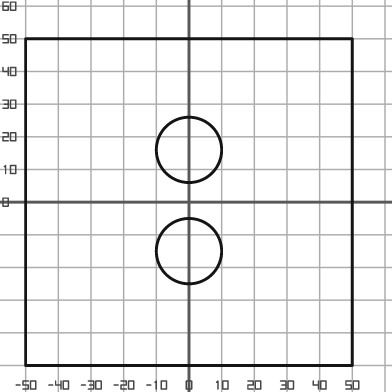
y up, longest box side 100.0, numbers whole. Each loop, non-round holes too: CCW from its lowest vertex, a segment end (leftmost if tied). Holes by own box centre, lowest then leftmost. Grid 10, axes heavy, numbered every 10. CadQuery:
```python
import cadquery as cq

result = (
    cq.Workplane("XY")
    .moveTo(-50.0, -50.0)
    .lineTo(50.0, -50.0)
    .lineTo(50.0, 50.0)
    .lineTo(-50.0, 50.0)
    .close()
    .moveTo(0.0, -15.0)
    .circle(10.0)
    .moveTo(0.0, 16.0)
    .circle(10.0)
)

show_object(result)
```